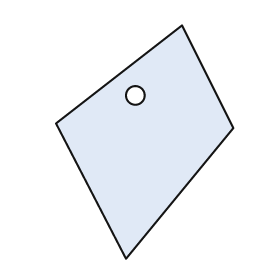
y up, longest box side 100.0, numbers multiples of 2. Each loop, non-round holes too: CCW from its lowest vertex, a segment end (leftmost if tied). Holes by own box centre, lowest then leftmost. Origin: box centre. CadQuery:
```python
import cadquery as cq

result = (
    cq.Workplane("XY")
    .moveTo(-8.0, -50.0)
    .lineTo(38.0, 6.0)
    .lineTo(16.0, 50.0)
    .lineTo(-38.0, 8.0)
    .close()
    .moveTo(-4.0, 20.0)
    .circle(4.0)
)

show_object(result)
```